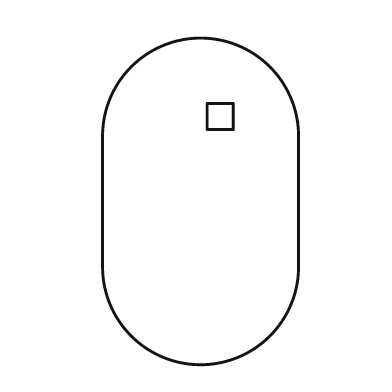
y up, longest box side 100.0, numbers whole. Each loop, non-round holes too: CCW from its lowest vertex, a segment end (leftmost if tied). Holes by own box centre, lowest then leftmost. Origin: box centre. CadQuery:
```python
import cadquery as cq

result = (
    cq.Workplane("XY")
    .moveTo(-30.0, -20.0)
    .threePointArc((0.0, -50.0), (30.0, -20.0))
    .lineTo(30.0, 20.0)
    .threePointArc((0.0, 50.0), (-30.0, 20.0))
    .close()
    .moveTo(2.0, 22.0)
    .lineTo(10.0, 22.0)
    .lineTo(10.0, 30.0)
    .lineTo(2.0, 30.0)
    .close()
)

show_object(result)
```